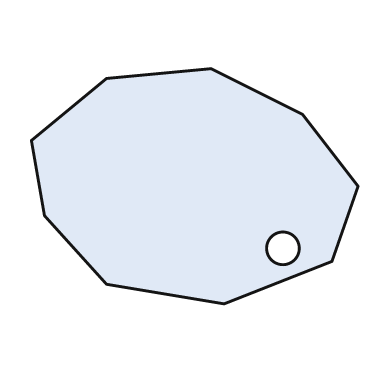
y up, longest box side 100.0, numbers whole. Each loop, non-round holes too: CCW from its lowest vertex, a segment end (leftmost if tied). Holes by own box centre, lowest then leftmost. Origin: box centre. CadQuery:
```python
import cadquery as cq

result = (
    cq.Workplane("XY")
    .moveTo(9.0, -36.0)
    .lineTo(42.0, -23.0)
    .lineTo(50.0, 0.0)
    .lineTo(33.0, 22.0)
    .lineTo(5.0, 36.0)
    .lineTo(-27.0, 33.0)
    .lineTo(-50.0, 14.0)
    .lineTo(-46.0, -9.0)
    .lineTo(-27.0, -30.0)
    .close()
    .moveTo(27.0, -19.0)
    .circle(5.0)
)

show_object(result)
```